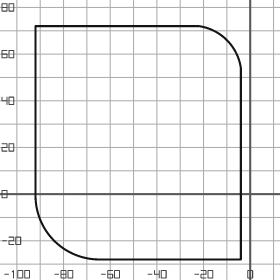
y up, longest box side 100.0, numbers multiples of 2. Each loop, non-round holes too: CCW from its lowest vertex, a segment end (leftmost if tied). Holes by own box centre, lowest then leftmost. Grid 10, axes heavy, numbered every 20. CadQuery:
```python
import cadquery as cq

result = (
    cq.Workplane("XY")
    .moveTo(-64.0, -28.0)
    .lineTo(-4.0, -28.0)
    .lineTo(-4.0, 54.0)
    .threePointArc((-10.0, 66.0), (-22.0, 72.0))
    .lineTo(-92.0, 72.0)
    .lineTo(-92.0, 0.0)
    .threePointArc((-84.0, -20.0), (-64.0, -28.0))
    .close()
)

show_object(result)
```